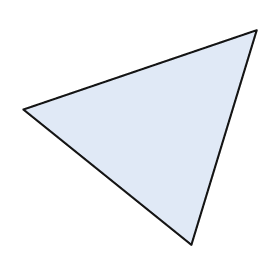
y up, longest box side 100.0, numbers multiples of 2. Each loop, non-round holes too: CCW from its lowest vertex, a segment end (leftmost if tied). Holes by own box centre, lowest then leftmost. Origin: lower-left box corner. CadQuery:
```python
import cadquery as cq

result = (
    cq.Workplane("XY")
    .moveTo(72.0, 0.0)
    .lineTo(100.0, 92.0)
    .lineTo(0.0, 58.0)
    .close()
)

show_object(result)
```